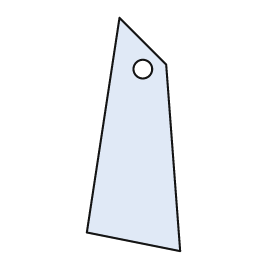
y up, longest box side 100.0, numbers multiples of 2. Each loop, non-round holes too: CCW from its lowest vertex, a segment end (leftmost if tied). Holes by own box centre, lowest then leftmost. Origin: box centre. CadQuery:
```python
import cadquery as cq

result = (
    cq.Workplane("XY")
    .moveTo(20.0, -50.0)
    .lineTo(14.0, 30.0)
    .lineTo(-6.0, 50.0)
    .lineTo(-20.0, -42.0)
    .close()
    .moveTo(4.0, 28.0)
    .circle(4.0)
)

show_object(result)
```